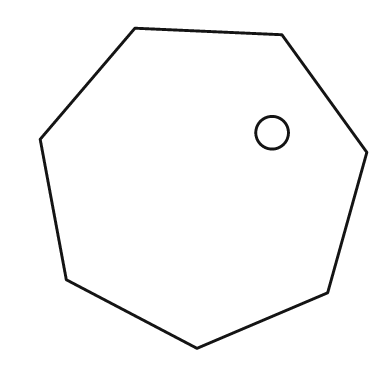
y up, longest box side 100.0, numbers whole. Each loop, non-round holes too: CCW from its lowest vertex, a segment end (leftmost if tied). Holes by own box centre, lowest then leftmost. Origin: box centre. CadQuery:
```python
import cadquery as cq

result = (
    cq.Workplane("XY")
    .moveTo(-2.0, -49.0)
    .lineTo(38.0, -32.0)
    .lineTo(50.0, 11.0)
    .lineTo(24.0, 47.0)
    .lineTo(-21.0, 49.0)
    .lineTo(-50.0, 15.0)
    .lineTo(-42.0, -28.0)
    .close()
    .moveTo(21.0, 17.0)
    .circle(5.0)
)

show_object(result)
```